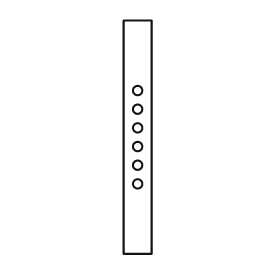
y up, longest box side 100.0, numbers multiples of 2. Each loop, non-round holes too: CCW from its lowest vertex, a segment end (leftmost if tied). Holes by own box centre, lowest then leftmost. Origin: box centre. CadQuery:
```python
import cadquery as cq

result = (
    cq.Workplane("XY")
    .moveTo(-6.0, -50.0)
    .lineTo(6.0, -50.0)
    .lineTo(6.0, 50.0)
    .lineTo(-6.0, 50.0)
    .close()
    .moveTo(0.0, -20.0)
    .circle(2.0)
    .moveTo(0.0, -12.0)
    .circle(2.0)
    .moveTo(0.0, -4.0)
    .circle(2.0)
    .moveTo(0.0, 4.0)
    .circle(2.0)
    .moveTo(0.0, 12.0)
    .circle(2.0)
    .moveTo(0.0, 20.0)
    .circle(2.0)
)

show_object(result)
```